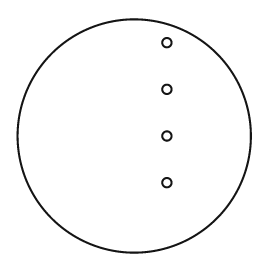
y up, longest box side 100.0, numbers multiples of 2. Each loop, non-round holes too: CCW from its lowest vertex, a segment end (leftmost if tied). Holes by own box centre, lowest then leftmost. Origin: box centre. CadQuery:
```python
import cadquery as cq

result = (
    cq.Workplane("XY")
    .moveTo(0.0, 0.0)
    .circle(50.0)
    .moveTo(14.0, -20.0)
    .circle(2.0)
    .moveTo(14.0, 0.0)
    .circle(2.0)
    .moveTo(14.0, 20.0)
    .circle(2.0)
    .moveTo(14.0, 40.0)
    .circle(2.0)
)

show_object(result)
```